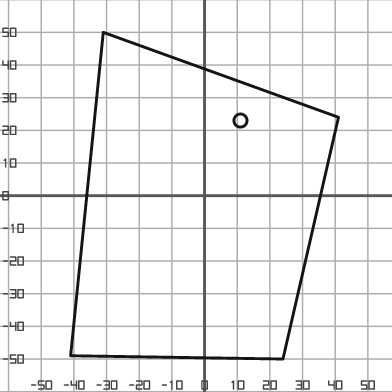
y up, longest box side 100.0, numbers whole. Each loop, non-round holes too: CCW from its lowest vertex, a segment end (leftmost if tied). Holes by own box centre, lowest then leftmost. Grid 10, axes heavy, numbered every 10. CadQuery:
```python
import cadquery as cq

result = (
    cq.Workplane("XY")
    .moveTo(24.0, -50.0)
    .lineTo(41.0, 24.0)
    .lineTo(-31.0, 50.0)
    .lineTo(-41.0, -49.0)
    .close()
    .moveTo(11.0, 23.0)
    .circle(2.0)
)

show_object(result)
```